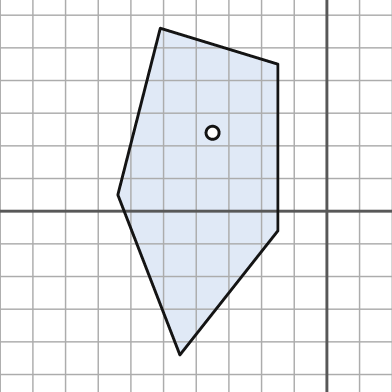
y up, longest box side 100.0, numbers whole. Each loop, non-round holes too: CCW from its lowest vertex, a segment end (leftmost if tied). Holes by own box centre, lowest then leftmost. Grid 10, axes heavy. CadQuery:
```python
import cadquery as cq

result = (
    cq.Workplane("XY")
    .moveTo(-45.0, -44.0)
    .lineTo(-15.0, -6.0)
    .lineTo(-15.0, 45.0)
    .lineTo(-51.0, 56.0)
    .lineTo(-64.0, 5.0)
    .close()
    .moveTo(-35.0, 24.0)
    .circle(2.0)
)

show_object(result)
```